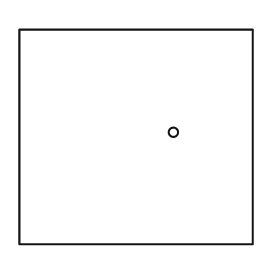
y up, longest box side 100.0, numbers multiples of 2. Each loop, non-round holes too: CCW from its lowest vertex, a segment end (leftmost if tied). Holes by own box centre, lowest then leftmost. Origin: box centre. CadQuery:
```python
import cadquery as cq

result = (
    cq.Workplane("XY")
    .moveTo(-50.0, -46.0)
    .lineTo(50.0, -46.0)
    .lineTo(50.0, 46.0)
    .lineTo(-50.0, 46.0)
    .close()
    .moveTo(16.0, 2.0)
    .circle(2.0)
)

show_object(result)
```